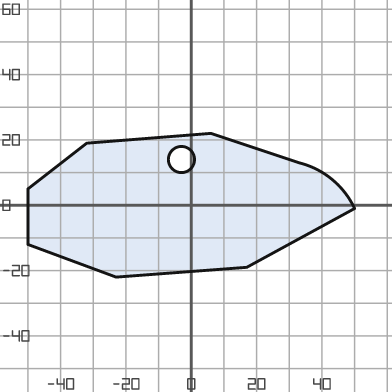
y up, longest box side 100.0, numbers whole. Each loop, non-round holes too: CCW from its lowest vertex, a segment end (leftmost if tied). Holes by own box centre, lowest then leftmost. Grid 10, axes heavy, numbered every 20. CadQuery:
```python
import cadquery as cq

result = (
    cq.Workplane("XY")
    .moveTo(-23.0, -22.0)
    .lineTo(17.0, -19.0)
    .lineTo(50.0, -1.0)
    .threePointArc((43.0, 8.0), (33.0, 13.0))
    .lineTo(6.0, 22.0)
    .lineTo(-32.0, 19.0)
    .lineTo(-50.0, 5.0)
    .lineTo(-50.0, -12.0)
    .close()
    .moveTo(-3.0, 14.0)
    .circle(4.0)
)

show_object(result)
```